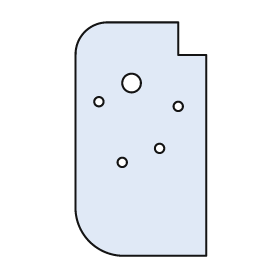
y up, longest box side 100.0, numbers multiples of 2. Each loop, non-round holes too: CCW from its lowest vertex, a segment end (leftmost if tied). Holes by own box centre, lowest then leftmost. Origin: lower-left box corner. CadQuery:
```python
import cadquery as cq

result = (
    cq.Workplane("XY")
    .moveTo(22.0, 0.0)
    .lineTo(56.0, 0.0)
    .lineTo(56.0, 86.0)
    .lineTo(44.0, 86.0)
    .lineTo(44.0, 100.0)
    .lineTo(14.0, 100.0)
    .threePointArc((4.0, 96.0), (0.0, 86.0))
    .lineTo(0.0, 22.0)
    .threePointArc((6.0, 6.0), (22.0, 0.0))
    .close()
    .moveTo(20.0, 40.0)
    .circle(2.0)
    .moveTo(36.0, 46.0)
    .circle(2.0)
    .moveTo(44.0, 64.0)
    .circle(2.0)
    .moveTo(10.0, 66.0)
    .circle(2.0)
    .moveTo(24.0, 74.0)
    .circle(4.0)
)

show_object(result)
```